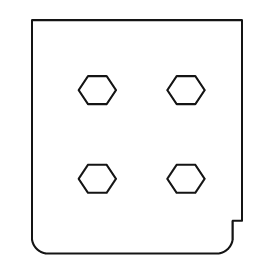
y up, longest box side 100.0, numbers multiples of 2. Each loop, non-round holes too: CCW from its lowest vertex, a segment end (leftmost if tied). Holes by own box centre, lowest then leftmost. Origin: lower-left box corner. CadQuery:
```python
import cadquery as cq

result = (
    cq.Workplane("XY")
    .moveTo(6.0, 0.0)
    .lineTo(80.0, 0.0)
    .threePointArc((84.0, 2.0), (86.0, 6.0))
    .lineTo(86.0, 14.0)
    .lineTo(90.0, 14.0)
    .lineTo(90.0, 100.0)
    .lineTo(0.0, 100.0)
    .lineTo(0.0, 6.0)
    .threePointArc((2.0, 2.0), (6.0, 0.0))
    .close()
    .moveTo(24.0, 26.0)
    .lineTo(32.0, 26.0)
    .lineTo(36.0, 32.0)
    .lineTo(32.0, 38.0)
    .lineTo(24.0, 38.0)
    .lineTo(20.0, 32.0)
    .close()
    .moveTo(62.0, 26.0)
    .lineTo(70.0, 26.0)
    .lineTo(74.0, 32.0)
    .lineTo(70.0, 38.0)
    .lineTo(62.0, 38.0)
    .lineTo(58.0, 32.0)
    .close()
    .moveTo(24.0, 64.0)
    .lineTo(32.0, 64.0)
    .lineTo(36.0, 70.0)
    .lineTo(32.0, 76.0)
    .lineTo(24.0, 76.0)
    .lineTo(20.0, 70.0)
    .close()
    .moveTo(62.0, 64.0)
    .lineTo(70.0, 64.0)
    .lineTo(74.0, 70.0)
    .lineTo(70.0, 76.0)
    .lineTo(62.0, 76.0)
    .lineTo(58.0, 70.0)
    .close()
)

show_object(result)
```